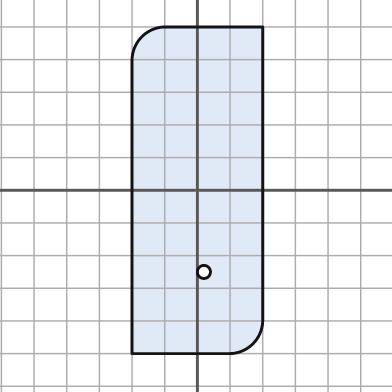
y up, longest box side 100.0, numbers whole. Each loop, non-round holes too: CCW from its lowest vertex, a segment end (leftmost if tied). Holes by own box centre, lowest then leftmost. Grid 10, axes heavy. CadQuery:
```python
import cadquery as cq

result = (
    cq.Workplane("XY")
    .moveTo(-20.0, -50.0)
    .lineTo(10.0, -50.0)
    .threePointArc((17.0, -47.0), (20.0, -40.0))
    .lineTo(20.0, 50.0)
    .lineTo(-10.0, 50.0)
    .threePointArc((-17.0, 47.0), (-20.0, 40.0))
    .close()
    .moveTo(2.0, -25.0)
    .circle(2.0)
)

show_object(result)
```